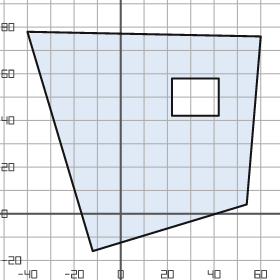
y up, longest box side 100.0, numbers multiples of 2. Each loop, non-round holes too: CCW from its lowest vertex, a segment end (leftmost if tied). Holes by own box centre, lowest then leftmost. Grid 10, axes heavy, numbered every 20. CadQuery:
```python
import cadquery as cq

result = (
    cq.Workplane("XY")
    .moveTo(-12.0, -16.0)
    .lineTo(54.0, 4.0)
    .lineTo(60.0, 76.0)
    .lineTo(-40.0, 78.0)
    .close()
    .moveTo(22.0, 42.0)
    .lineTo(42.0, 42.0)
    .lineTo(42.0, 58.0)
    .lineTo(22.0, 58.0)
    .close()
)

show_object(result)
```